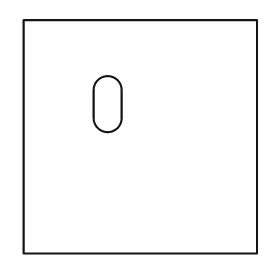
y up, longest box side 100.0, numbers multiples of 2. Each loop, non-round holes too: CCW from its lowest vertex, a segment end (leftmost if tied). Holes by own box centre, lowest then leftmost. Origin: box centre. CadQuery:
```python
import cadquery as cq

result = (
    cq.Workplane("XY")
    .moveTo(-50.0, -50.0)
    .lineTo(50.0, -50.0)
    .lineTo(50.0, 50.0)
    .lineTo(-50.0, 50.0)
    .close()
    .moveTo(-20.0, 8.0)
    .threePointArc((-14.0, 2.0), (-8.0, 8.0))
    .lineTo(-8.0, 20.0)
    .threePointArc((-14.0, 26.0), (-20.0, 20.0))
    .close()
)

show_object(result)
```